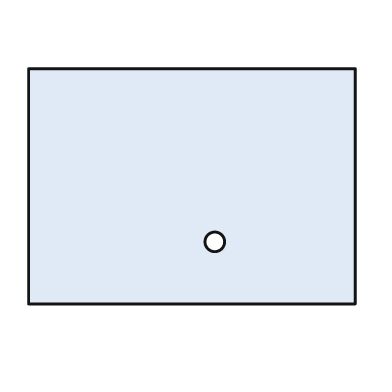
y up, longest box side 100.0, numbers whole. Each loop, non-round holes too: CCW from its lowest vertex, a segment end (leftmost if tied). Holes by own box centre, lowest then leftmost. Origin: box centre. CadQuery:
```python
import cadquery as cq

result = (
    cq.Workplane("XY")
    .moveTo(-50.0, -36.0)
    .lineTo(50.0, -36.0)
    .lineTo(50.0, 36.0)
    .lineTo(-50.0, 36.0)
    .close()
    .moveTo(7.0, -17.0)
    .circle(3.0)
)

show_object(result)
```